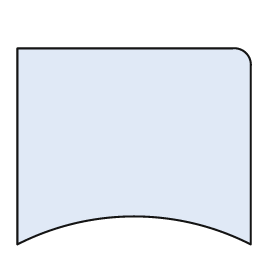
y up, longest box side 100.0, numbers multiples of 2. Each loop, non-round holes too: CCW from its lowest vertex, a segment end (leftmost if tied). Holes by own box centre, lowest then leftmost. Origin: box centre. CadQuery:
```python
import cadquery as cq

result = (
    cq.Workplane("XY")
    .moveTo(-50.0, -42.0)
    .threePointArc((0.0, -30.0), (50.0, -42.0))
    .lineTo(50.0, 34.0)
    .threePointArc((48.0, 40.0), (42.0, 42.0))
    .lineTo(-50.0, 42.0)
    .close()
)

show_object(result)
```